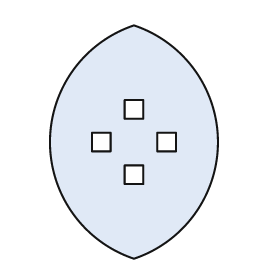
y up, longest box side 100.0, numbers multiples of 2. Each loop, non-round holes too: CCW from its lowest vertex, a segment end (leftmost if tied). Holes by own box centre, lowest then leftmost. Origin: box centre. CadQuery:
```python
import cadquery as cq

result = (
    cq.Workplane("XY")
    .moveTo(0.0, -50.0)
    .threePointArc((36.0, 0.0), (0.0, 50.0))
    .threePointArc((-36.0, 0.0), (0.0, -50.0))
    .close()
    .moveTo(-4.0, -18.0)
    .lineTo(4.0, -18.0)
    .lineTo(4.0, -10.0)
    .lineTo(-4.0, -10.0)
    .close()
    .moveTo(-18.0, -4.0)
    .lineTo(-10.0, -4.0)
    .lineTo(-10.0, 4.0)
    .lineTo(-18.0, 4.0)
    .close()
    .moveTo(10.0, -4.0)
    .lineTo(18.0, -4.0)
    .lineTo(18.0, 4.0)
    .lineTo(10.0, 4.0)
    .close()
    .moveTo(-4.0, 10.0)
    .lineTo(4.0, 10.0)
    .lineTo(4.0, 18.0)
    .lineTo(-4.0, 18.0)
    .close()
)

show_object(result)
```